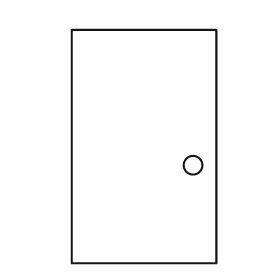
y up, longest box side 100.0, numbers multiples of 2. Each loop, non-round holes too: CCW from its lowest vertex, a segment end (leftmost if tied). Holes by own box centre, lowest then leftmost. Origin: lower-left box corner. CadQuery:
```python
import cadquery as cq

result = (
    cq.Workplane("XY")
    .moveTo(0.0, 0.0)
    .lineTo(62.0, 0.0)
    .lineTo(62.0, 100.0)
    .lineTo(0.0, 100.0)
    .close()
    .moveTo(52.0, 42.0)
    .circle(4.0)
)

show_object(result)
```